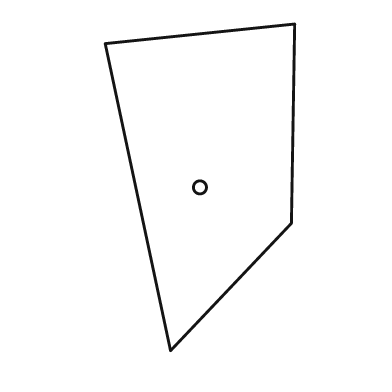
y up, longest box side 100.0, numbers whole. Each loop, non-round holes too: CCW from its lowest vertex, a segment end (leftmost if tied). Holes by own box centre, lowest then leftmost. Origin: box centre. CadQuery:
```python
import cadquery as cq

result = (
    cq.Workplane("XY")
    .moveTo(-9.0, -50.0)
    .lineTo(28.0, -11.0)
    .lineTo(29.0, 50.0)
    .lineTo(-29.0, 44.0)
    .close()
    .moveTo(0.0, 0.0)
    .circle(2.0)
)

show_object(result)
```